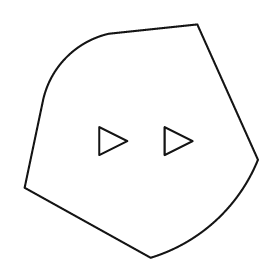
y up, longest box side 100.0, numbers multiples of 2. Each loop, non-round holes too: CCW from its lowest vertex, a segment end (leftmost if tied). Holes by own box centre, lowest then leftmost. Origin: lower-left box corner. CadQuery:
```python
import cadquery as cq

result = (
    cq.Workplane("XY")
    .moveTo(54.0, 0.0)
    .threePointArc((82.0, 16.0), (100.0, 42.0))
    .lineTo(74.0, 100.0)
    .lineTo(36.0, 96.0)
    .threePointArc((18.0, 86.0), (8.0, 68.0))
    .lineTo(0.0, 30.0)
    .close()
    .moveTo(32.0, 44.0)
    .lineTo(44.0, 50.0)
    .lineTo(32.0, 56.0)
    .close()
    .moveTo(60.0, 44.0)
    .lineTo(72.0, 50.0)
    .lineTo(60.0, 56.0)
    .close()
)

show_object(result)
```